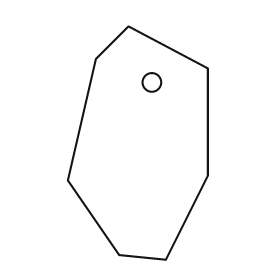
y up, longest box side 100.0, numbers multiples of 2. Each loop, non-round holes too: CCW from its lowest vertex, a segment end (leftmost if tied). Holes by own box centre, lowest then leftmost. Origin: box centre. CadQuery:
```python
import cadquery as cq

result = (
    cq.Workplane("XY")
    .moveTo(12.0, -50.0)
    .lineTo(30.0, -14.0)
    .lineTo(30.0, 32.0)
    .lineTo(-4.0, 50.0)
    .lineTo(-18.0, 36.0)
    .lineTo(-30.0, -16.0)
    .lineTo(-8.0, -48.0)
    .close()
    .moveTo(6.0, 26.0)
    .circle(4.0)
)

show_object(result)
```